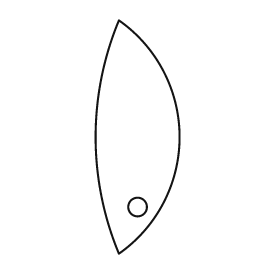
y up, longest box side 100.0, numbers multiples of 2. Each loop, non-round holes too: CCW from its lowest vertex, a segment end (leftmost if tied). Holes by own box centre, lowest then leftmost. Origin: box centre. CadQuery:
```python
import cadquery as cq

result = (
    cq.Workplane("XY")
    .moveTo(-8.0, -50.0)
    .threePointArc((18.0, 0.0), (-8.0, 50.0))
    .threePointArc((-18.0, 0.0), (-8.0, -50.0))
    .close()
    .moveTo(0.0, -30.0)
    .circle(4.0)
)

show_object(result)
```